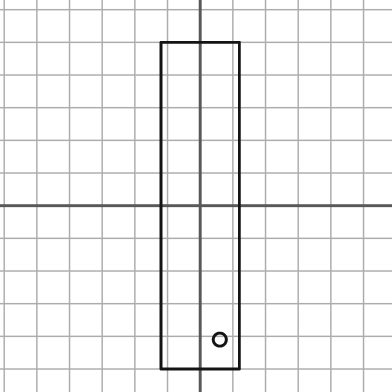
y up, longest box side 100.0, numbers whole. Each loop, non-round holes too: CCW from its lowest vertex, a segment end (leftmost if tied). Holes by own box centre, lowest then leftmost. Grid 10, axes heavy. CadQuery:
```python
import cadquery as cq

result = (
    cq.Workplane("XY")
    .moveTo(-12.0, -50.0)
    .lineTo(12.0, -50.0)
    .lineTo(12.0, 50.0)
    .lineTo(-12.0, 50.0)
    .close()
    .moveTo(6.0, -41.0)
    .circle(2.0)
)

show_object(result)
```